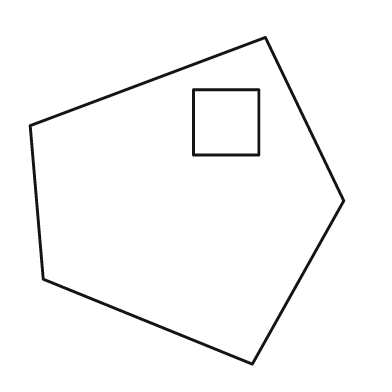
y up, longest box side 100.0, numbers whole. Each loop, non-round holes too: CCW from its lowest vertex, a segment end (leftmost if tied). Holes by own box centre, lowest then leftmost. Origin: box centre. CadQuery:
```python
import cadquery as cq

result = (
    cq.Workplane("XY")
    .moveTo(20.0, -50.0)
    .lineTo(48.0, 0.0)
    .lineTo(24.0, 50.0)
    .lineTo(-48.0, 23.0)
    .lineTo(-44.0, -24.0)
    .close()
    .moveTo(2.0, 14.0)
    .lineTo(22.0, 14.0)
    .lineTo(22.0, 34.0)
    .lineTo(2.0, 34.0)
    .close()
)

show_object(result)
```